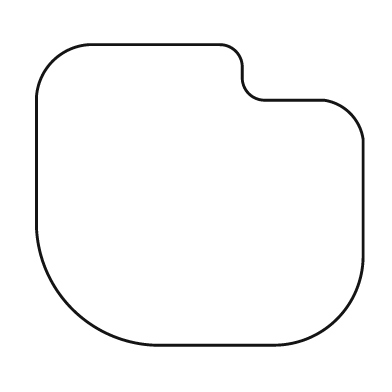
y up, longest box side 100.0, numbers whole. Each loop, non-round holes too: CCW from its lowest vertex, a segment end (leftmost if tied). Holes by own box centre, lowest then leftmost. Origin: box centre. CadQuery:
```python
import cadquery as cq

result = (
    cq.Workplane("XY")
    .moveTo(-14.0, -46.0)
    .lineTo(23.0, -46.0)
    .threePointArc((42.0, -38.0), (50.0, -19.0))
    .lineTo(50.0, 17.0)
    .threePointArc((46.0, 25.0), (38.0, 29.0))
    .lineTo(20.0, 29.0)
    .threePointArc((15.0, 31.0), (13.0, 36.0))
    .lineTo(13.0, 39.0)
    .threePointArc((11.0, 44.0), (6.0, 46.0))
    .lineTo(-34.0, 46.0)
    .threePointArc((-45.0, 41.0), (-50.0, 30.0))
    .lineTo(-50.0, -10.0)
    .threePointArc((-39.0, -35.0), (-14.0, -46.0))
    .close()
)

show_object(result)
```